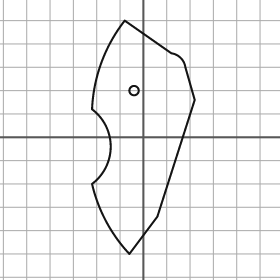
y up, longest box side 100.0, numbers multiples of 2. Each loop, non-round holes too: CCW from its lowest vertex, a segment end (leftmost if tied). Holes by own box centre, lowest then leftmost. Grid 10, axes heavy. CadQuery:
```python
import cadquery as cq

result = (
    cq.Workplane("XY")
    .moveTo(-6.0, -50.0)
    .lineTo(6.0, -34.0)
    .lineTo(22.0, 16.0)
    .lineTo(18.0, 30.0)
    .threePointArc((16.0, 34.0), (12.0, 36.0))
    .lineTo(-8.0, 50.0)
    .threePointArc((-18.0, 32.0), (-22.0, 12.0))
    .threePointArc((-14.0, -4.0), (-22.0, -20.0))
    .threePointArc((-16.0, -36.0), (-6.0, -50.0))
    .close()
    .moveTo(-4.0, 20.0)
    .circle(2.0)
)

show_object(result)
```